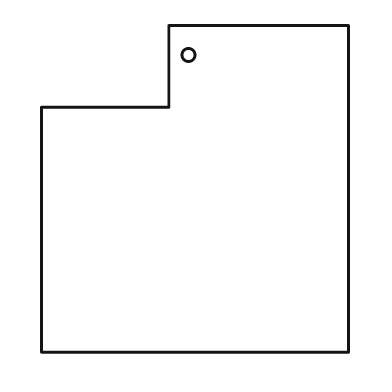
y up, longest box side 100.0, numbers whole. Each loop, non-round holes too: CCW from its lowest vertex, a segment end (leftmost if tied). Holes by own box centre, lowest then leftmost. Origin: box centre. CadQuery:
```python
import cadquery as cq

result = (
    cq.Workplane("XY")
    .moveTo(-47.0, -50.0)
    .lineTo(47.0, -50.0)
    .lineTo(47.0, 50.0)
    .lineTo(-8.0, 50.0)
    .lineTo(-8.0, 25.0)
    .lineTo(-47.0, 25.0)
    .close()
    .moveTo(-2.0, 41.0)
    .circle(2.0)
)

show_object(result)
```